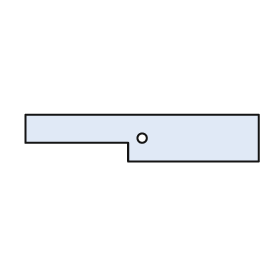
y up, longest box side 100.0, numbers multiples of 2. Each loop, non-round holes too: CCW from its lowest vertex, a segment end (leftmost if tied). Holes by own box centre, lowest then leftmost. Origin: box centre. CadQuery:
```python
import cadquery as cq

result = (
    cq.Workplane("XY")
    .moveTo(-6.0, -10.0)
    .lineTo(50.0, -10.0)
    .lineTo(50.0, 10.0)
    .lineTo(-50.0, 10.0)
    .lineTo(-50.0, -2.0)
    .lineTo(-6.0, -2.0)
    .close()
    .moveTo(0.0, 0.0)
    .circle(2.0)
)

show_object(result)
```